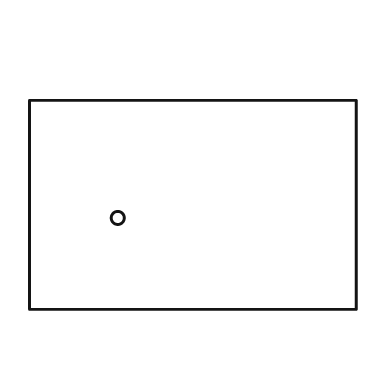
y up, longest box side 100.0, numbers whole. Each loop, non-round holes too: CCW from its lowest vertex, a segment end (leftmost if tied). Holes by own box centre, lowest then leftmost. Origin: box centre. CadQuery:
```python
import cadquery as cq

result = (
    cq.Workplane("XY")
    .moveTo(-50.0, -32.0)
    .lineTo(50.0, -32.0)
    .lineTo(50.0, 32.0)
    .lineTo(-50.0, 32.0)
    .close()
    .moveTo(-23.0, -4.0)
    .circle(2.0)
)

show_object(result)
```